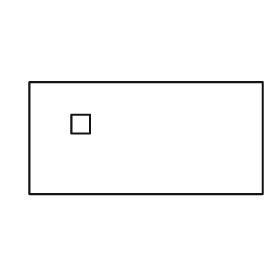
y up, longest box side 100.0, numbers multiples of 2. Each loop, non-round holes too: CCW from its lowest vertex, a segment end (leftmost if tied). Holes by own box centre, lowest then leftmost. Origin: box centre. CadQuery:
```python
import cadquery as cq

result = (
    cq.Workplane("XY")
    .moveTo(-50.0, -24.0)
    .lineTo(50.0, -24.0)
    .lineTo(50.0, 24.0)
    .lineTo(-50.0, 24.0)
    .close()
    .moveTo(-32.0, 2.0)
    .lineTo(-24.0, 2.0)
    .lineTo(-24.0, 10.0)
    .lineTo(-32.0, 10.0)
    .close()
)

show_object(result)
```